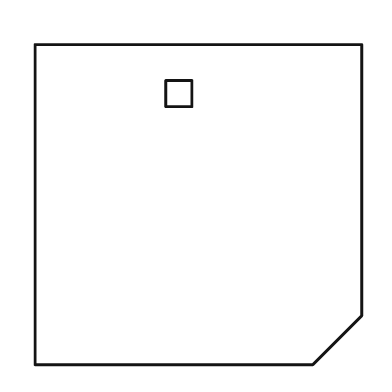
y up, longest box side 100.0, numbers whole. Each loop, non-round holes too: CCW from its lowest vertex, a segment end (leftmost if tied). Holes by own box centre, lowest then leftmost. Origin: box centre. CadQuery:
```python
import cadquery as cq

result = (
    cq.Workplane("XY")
    .moveTo(-50.0, -49.0)
    .lineTo(35.0, -49.0)
    .lineTo(50.0, -34.0)
    .lineTo(50.0, 49.0)
    .lineTo(-50.0, 49.0)
    .close()
    .moveTo(-10.0, 30.0)
    .lineTo(-2.0, 30.0)
    .lineTo(-2.0, 38.0)
    .lineTo(-10.0, 38.0)
    .close()
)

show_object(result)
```